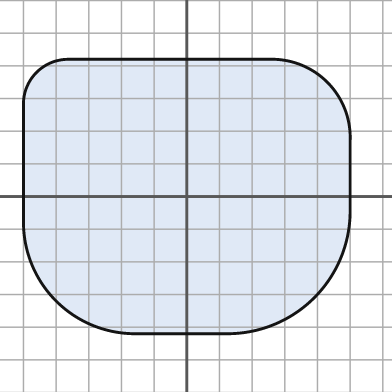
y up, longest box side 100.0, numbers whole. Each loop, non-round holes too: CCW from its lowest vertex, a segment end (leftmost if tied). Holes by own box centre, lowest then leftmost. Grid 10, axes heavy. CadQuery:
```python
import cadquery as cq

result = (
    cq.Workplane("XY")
    .moveTo(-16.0, -42.0)
    .lineTo(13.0, -42.0)
    .threePointArc((39.0, -31.0), (50.0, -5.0))
    .lineTo(50.0, 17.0)
    .threePointArc((43.0, 35.0), (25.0, 42.0))
    .lineTo(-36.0, 42.0)
    .threePointArc((-46.0, 38.0), (-50.0, 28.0))
    .lineTo(-50.0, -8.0)
    .threePointArc((-40.0, -32.0), (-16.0, -42.0))
    .close()
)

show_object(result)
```